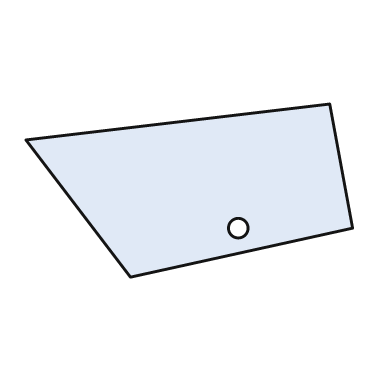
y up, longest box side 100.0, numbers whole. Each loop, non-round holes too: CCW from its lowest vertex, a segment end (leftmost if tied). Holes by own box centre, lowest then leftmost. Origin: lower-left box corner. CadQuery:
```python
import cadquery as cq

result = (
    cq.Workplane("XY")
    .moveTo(32.0, 0.0)
    .lineTo(100.0, 15.0)
    .lineTo(93.0, 53.0)
    .lineTo(0.0, 42.0)
    .close()
    .moveTo(65.0, 15.0)
    .circle(3.0)
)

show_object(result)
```